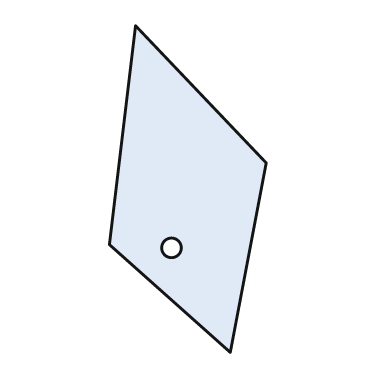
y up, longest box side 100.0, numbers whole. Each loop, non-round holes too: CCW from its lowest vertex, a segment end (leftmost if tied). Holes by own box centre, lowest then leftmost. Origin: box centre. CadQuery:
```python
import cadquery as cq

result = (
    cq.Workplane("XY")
    .moveTo(13.0, -50.0)
    .lineTo(24.0, 8.0)
    .lineTo(-16.0, 50.0)
    .lineTo(-24.0, -17.0)
    .close()
    .moveTo(-5.0, -18.0)
    .circle(3.0)
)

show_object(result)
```